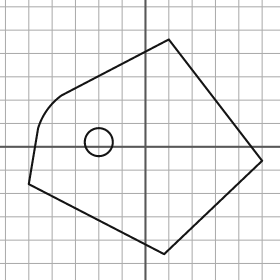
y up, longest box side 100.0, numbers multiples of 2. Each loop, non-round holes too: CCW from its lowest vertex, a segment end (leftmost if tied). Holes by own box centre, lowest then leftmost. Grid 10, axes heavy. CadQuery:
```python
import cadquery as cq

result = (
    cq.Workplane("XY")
    .moveTo(8.0, -46.0)
    .lineTo(50.0, -6.0)
    .lineTo(10.0, 46.0)
    .lineTo(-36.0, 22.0)
    .threePointArc((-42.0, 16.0), (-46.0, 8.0))
    .lineTo(-50.0, -16.0)
    .close()
    .moveTo(-20.0, 2.0)
    .circle(6.0)
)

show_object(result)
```